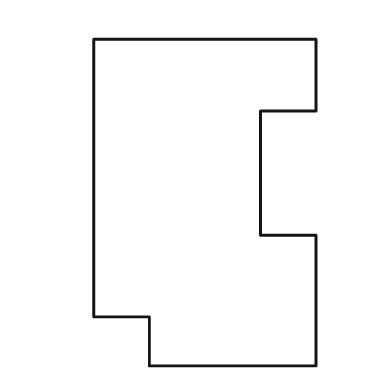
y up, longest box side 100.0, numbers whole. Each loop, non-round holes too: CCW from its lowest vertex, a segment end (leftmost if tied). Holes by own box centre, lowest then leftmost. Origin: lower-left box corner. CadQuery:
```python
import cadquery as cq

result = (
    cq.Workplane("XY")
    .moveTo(17.0, 0.0)
    .lineTo(68.0, 0.0)
    .lineTo(68.0, 40.0)
    .lineTo(51.0, 40.0)
    .lineTo(51.0, 78.0)
    .lineTo(68.0, 78.0)
    .lineTo(68.0, 100.0)
    .lineTo(0.0, 100.0)
    .lineTo(0.0, 15.0)
    .lineTo(17.0, 15.0)
    .close()
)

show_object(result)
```